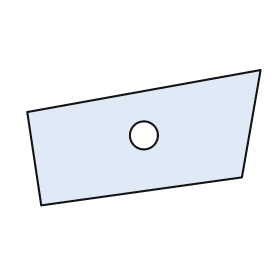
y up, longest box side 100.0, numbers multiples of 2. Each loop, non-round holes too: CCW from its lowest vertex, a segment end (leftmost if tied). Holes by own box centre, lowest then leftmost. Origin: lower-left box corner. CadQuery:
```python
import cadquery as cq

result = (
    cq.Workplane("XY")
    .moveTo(6.0, 0.0)
    .lineTo(92.0, 12.0)
    .lineTo(100.0, 58.0)
    .lineTo(0.0, 40.0)
    .close()
    .moveTo(50.0, 30.0)
    .circle(6.0)
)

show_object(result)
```